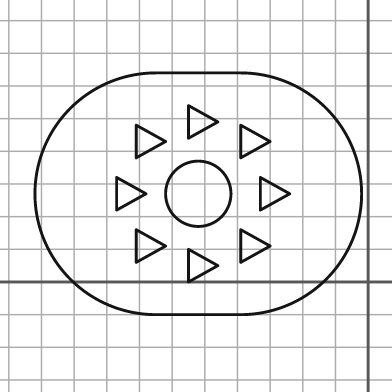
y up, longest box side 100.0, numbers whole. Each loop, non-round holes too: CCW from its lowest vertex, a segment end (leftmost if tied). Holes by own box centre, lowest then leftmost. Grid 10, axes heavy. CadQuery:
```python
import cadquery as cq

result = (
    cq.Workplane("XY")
    .moveTo(-65.0, -10.0)
    .lineTo(-39.0, -10.0)
    .threePointArc((-2.0, 27.0), (-39.0, 64.0))
    .lineTo(-65.0, 64.0)
    .threePointArc((-102.0, 27.0), (-65.0, -10.0))
    .close()
    .moveTo(-55.0, 0.0)
    .lineTo(-46.0, 5.0)
    .lineTo(-55.0, 10.0)
    .close()
    .moveTo(-71.0, 6.0)
    .lineTo(-62.0, 11.0)
    .lineTo(-71.0, 16.0)
    .close()
    .moveTo(-39.0, 6.0)
    .lineTo(-30.0, 11.0)
    .lineTo(-39.0, 16.0)
    .close()
    .moveTo(-77.0, 22.0)
    .lineTo(-68.0, 27.0)
    .lineTo(-77.0, 32.0)
    .close()
    .moveTo(-52.0, 27.0)
    .circle(10.0)
    .moveTo(-33.0, 22.0)
    .lineTo(-24.0, 27.0)
    .lineTo(-33.0, 32.0)
    .close()
    .moveTo(-71.0, 38.0)
    .lineTo(-62.0, 43.0)
    .lineTo(-71.0, 48.0)
    .close()
    .moveTo(-39.0, 38.0)
    .lineTo(-30.0, 43.0)
    .lineTo(-39.0, 48.0)
    .close()
    .moveTo(-55.0, 44.0)
    .lineTo(-46.0, 49.0)
    .lineTo(-55.0, 54.0)
    .close()
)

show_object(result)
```